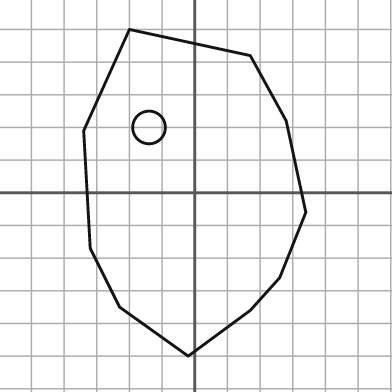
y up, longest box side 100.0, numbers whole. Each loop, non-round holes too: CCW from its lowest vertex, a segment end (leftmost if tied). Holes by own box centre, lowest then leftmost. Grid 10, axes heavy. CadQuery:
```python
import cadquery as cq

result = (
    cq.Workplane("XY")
    .moveTo(-2.0, -50.0)
    .lineTo(17.0, -36.0)
    .lineTo(26.0, -26.0)
    .lineTo(34.0, -6.0)
    .lineTo(28.0, 22.0)
    .lineTo(17.0, 42.0)
    .lineTo(-20.0, 50.0)
    .lineTo(-34.0, 19.0)
    .lineTo(-32.0, -17.0)
    .lineTo(-23.0, -35.0)
    .close()
    .moveTo(-14.0, 20.0)
    .circle(5.0)
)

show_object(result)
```